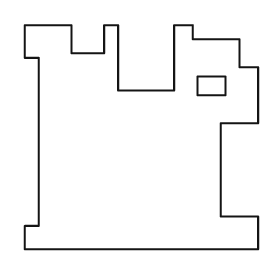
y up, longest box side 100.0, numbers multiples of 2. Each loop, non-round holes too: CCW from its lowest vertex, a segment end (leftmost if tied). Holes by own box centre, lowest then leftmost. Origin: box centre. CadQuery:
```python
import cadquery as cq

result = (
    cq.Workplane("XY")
    .moveTo(-50.0, -48.0)
    .lineTo(50.0, -48.0)
    .lineTo(50.0, -34.0)
    .lineTo(34.0, -34.0)
    .lineTo(34.0, 6.0)
    .lineTo(50.0, 6.0)
    .lineTo(50.0, 30.0)
    .lineTo(42.0, 30.0)
    .lineTo(42.0, 42.0)
    .lineTo(22.0, 42.0)
    .lineTo(22.0, 48.0)
    .lineTo(14.0, 48.0)
    .lineTo(14.0, 20.0)
    .lineTo(-10.0, 20.0)
    .lineTo(-10.0, 48.0)
    .lineTo(-16.0, 48.0)
    .lineTo(-16.0, 36.0)
    .lineTo(-30.0, 36.0)
    .lineTo(-30.0, 48.0)
    .lineTo(-50.0, 48.0)
    .lineTo(-50.0, 34.0)
    .lineTo(-44.0, 34.0)
    .lineTo(-44.0, -38.0)
    .lineTo(-50.0, -38.0)
    .close()
    .moveTo(24.0, 18.0)
    .lineTo(36.0, 18.0)
    .lineTo(36.0, 26.0)
    .lineTo(24.0, 26.0)
    .close()
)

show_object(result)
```